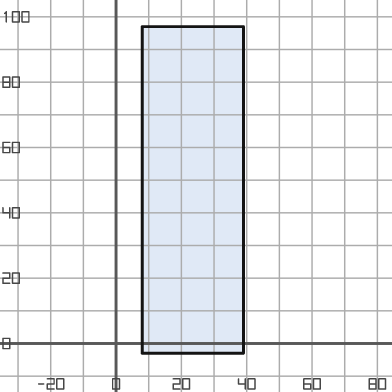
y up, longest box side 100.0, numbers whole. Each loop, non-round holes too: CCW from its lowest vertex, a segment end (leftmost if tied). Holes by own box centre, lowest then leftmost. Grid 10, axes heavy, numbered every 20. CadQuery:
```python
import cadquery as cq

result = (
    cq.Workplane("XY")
    .moveTo(8.0, -3.0)
    .lineTo(39.0, -3.0)
    .lineTo(39.0, 97.0)
    .lineTo(8.0, 97.0)
    .close()
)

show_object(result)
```